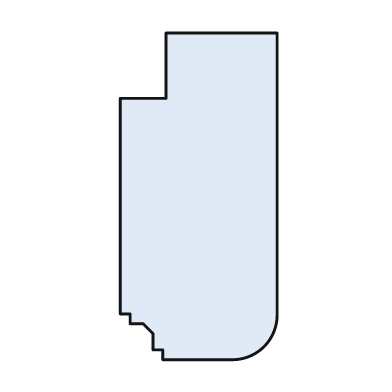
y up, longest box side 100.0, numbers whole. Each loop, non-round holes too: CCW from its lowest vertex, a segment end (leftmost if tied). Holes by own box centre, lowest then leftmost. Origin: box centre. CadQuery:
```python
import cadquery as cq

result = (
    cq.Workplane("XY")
    .moveTo(-11.0, -50.0)
    .lineTo(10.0, -50.0)
    .threePointArc((20.0, -46.0), (24.0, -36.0))
    .lineTo(24.0, 50.0)
    .lineTo(-10.0, 50.0)
    .lineTo(-10.0, 30.0)
    .lineTo(-24.0, 30.0)
    .lineTo(-24.0, -36.0)
    .lineTo(-21.0, -36.0)
    .lineTo(-21.0, -39.0)
    .lineTo(-17.0, -39.0)
    .lineTo(-14.0, -42.0)
    .lineTo(-14.0, -47.0)
    .lineTo(-11.0, -47.0)
    .close()
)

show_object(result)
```